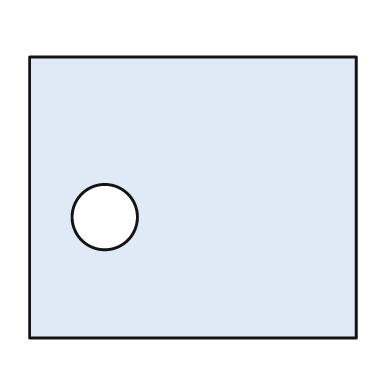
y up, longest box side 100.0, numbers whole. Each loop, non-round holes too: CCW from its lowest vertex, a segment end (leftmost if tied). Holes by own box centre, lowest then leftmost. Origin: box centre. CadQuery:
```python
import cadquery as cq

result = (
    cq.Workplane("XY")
    .moveTo(-50.0, -43.0)
    .lineTo(50.0, -43.0)
    .lineTo(50.0, 43.0)
    .lineTo(-50.0, 43.0)
    .close()
    .moveTo(-27.0, -6.0)
    .circle(10.0)
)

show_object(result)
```